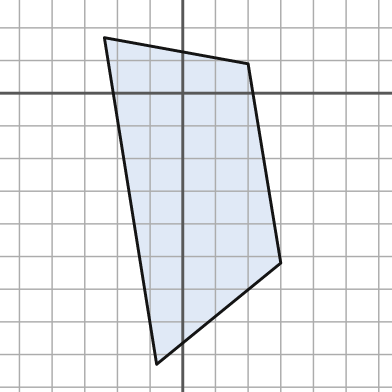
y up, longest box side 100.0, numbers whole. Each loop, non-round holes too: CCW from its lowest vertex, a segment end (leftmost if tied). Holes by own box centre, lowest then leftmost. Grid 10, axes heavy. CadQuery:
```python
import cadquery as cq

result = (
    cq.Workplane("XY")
    .moveTo(-8.0, -83.0)
    .lineTo(30.0, -52.0)
    .lineTo(20.0, 9.0)
    .lineTo(-24.0, 17.0)
    .close()
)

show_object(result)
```